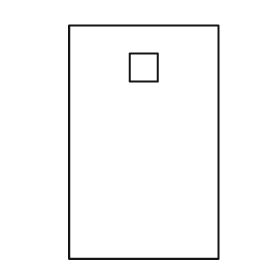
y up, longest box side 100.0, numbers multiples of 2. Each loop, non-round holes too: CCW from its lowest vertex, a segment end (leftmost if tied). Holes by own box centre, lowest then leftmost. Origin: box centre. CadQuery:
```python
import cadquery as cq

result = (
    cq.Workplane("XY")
    .moveTo(-32.0, -50.0)
    .lineTo(32.0, -50.0)
    .lineTo(32.0, 50.0)
    .lineTo(-32.0, 50.0)
    .close()
    .moveTo(-6.0, 26.0)
    .lineTo(6.0, 26.0)
    .lineTo(6.0, 38.0)
    .lineTo(-6.0, 38.0)
    .close()
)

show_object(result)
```